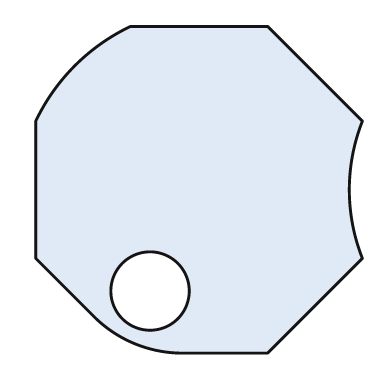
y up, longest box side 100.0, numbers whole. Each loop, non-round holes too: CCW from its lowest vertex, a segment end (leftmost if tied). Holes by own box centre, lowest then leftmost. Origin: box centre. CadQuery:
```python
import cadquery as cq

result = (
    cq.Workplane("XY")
    .moveTo(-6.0, -50.0)
    .lineTo(21.0, -50.0)
    .lineTo(50.0, -21.0)
    .threePointArc((46.0, 0.0), (50.0, 21.0))
    .lineTo(21.0, 50.0)
    .lineTo(-21.0, 50.0)
    .threePointArc((-38.0, 38.0), (-50.0, 21.0))
    .lineTo(-50.0, -21.0)
    .lineTo(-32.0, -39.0)
    .threePointArc((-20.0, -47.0), (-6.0, -50.0))
    .close()
    .moveTo(-15.0, -31.0)
    .circle(12.0)
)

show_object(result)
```